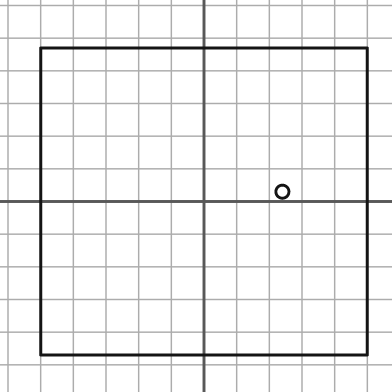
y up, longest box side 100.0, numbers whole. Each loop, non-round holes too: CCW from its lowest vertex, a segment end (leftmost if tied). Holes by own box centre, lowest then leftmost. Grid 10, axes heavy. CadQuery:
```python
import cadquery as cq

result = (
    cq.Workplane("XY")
    .moveTo(-50.0, -47.0)
    .lineTo(50.0, -47.0)
    .lineTo(50.0, 47.0)
    .lineTo(-50.0, 47.0)
    .close()
    .moveTo(24.0, 3.0)
    .circle(2.0)
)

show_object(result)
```